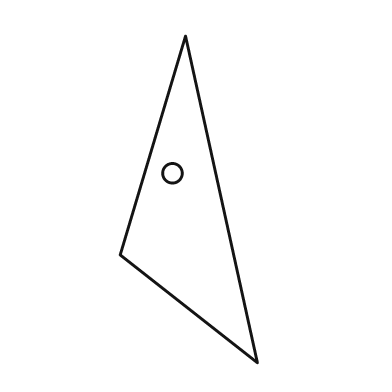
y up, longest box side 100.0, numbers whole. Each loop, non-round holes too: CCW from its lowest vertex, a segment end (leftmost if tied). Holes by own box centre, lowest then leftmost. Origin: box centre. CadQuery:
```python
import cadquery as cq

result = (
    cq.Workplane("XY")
    .moveTo(21.0, -50.0)
    .lineTo(-1.0, 50.0)
    .lineTo(-21.0, -17.0)
    .close()
    .moveTo(-5.0, 8.0)
    .circle(3.0)
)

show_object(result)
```